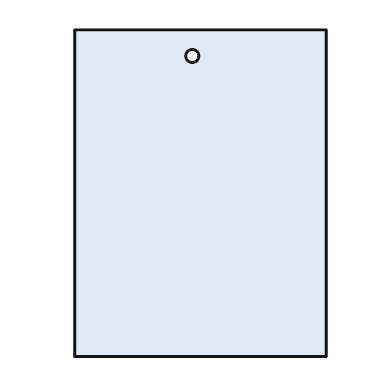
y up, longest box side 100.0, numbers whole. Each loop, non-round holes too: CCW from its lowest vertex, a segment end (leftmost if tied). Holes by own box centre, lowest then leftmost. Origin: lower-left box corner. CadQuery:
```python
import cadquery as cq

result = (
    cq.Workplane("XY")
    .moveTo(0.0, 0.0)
    .lineTo(77.0, 0.0)
    .lineTo(77.0, 100.0)
    .lineTo(0.0, 100.0)
    .close()
    .moveTo(36.0, 92.0)
    .circle(2.0)
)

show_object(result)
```